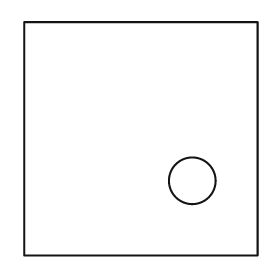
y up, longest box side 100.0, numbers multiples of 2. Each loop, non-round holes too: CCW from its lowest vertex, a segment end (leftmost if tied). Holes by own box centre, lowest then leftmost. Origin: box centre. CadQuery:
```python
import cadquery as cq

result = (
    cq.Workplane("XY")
    .moveTo(-50.0, -50.0)
    .lineTo(50.0, -50.0)
    .lineTo(50.0, 50.0)
    .lineTo(-50.0, 50.0)
    .close()
    .moveTo(22.0, -18.0)
    .circle(10.0)
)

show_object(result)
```